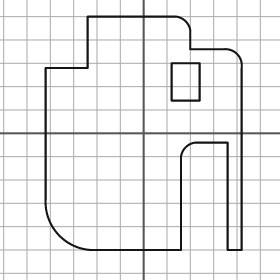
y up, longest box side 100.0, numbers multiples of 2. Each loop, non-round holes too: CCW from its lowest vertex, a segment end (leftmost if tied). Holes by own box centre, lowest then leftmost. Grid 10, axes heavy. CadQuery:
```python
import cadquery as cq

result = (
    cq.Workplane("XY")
    .moveTo(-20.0, -50.0)
    .lineTo(16.0, -50.0)
    .lineTo(16.0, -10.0)
    .threePointArc((18.0, -6.0), (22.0, -4.0))
    .lineTo(36.0, -4.0)
    .lineTo(36.0, -50.0)
    .lineTo(42.0, -50.0)
    .lineTo(42.0, 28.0)
    .threePointArc((40.0, 34.0), (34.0, 36.0))
    .lineTo(20.0, 36.0)
    .lineTo(20.0, 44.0)
    .threePointArc((18.0, 48.0), (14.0, 50.0))
    .lineTo(-24.0, 50.0)
    .lineTo(-24.0, 28.0)
    .lineTo(-42.0, 28.0)
    .lineTo(-42.0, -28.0)
    .threePointArc((-36.0, -44.0), (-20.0, -50.0))
    .close()
    .moveTo(12.0, 14.0)
    .lineTo(24.0, 14.0)
    .lineTo(24.0, 30.0)
    .lineTo(12.0, 30.0)
    .close()
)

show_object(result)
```